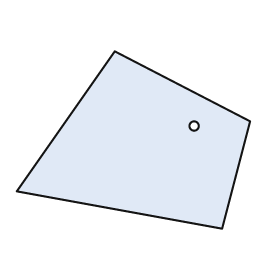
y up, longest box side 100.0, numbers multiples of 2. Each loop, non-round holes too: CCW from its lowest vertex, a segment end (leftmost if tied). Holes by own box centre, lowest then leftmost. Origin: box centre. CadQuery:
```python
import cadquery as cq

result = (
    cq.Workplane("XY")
    .moveTo(38.0, -38.0)
    .lineTo(50.0, 8.0)
    .lineTo(-8.0, 38.0)
    .lineTo(-50.0, -22.0)
    .close()
    .moveTo(26.0, 6.0)
    .circle(2.0)
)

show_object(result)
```